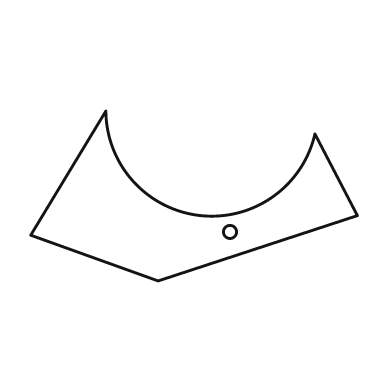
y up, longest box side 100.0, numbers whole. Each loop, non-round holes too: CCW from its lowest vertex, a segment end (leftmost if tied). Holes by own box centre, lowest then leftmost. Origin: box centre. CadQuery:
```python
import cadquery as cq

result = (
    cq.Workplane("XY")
    .moveTo(-11.0, -26.0)
    .lineTo(50.0, -6.0)
    .lineTo(37.0, 19.0)
    .threePointArc((2.0, -6.0), (-27.0, 26.0))
    .lineTo(-50.0, -12.0)
    .close()
    .moveTo(11.0, -11.0)
    .circle(2.0)
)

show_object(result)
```